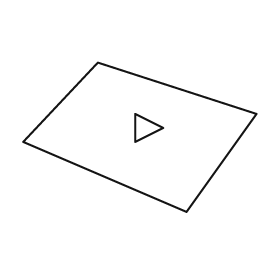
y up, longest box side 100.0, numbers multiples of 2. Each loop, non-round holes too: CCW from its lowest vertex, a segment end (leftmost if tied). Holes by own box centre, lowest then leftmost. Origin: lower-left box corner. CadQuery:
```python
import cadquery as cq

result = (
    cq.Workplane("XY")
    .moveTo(70.0, 0.0)
    .lineTo(100.0, 42.0)
    .lineTo(32.0, 64.0)
    .lineTo(0.0, 30.0)
    .close()
    .moveTo(48.0, 30.0)
    .lineTo(60.0, 36.0)
    .lineTo(48.0, 42.0)
    .close()
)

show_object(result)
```